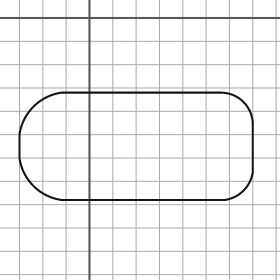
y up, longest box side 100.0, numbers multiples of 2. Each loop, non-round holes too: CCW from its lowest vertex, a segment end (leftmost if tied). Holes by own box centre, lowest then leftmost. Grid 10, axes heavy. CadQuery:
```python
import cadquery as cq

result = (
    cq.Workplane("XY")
    .moveTo(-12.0, -78.0)
    .lineTo(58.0, -78.0)
    .threePointArc((66.0, -74.0), (70.0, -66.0))
    .lineTo(70.0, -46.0)
    .threePointArc((66.0, -36.0), (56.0, -32.0))
    .lineTo(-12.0, -32.0)
    .threePointArc((-24.0, -38.0), (-30.0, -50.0))
    .lineTo(-30.0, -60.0)
    .threePointArc((-24.0, -72.0), (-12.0, -78.0))
    .close()
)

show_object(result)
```